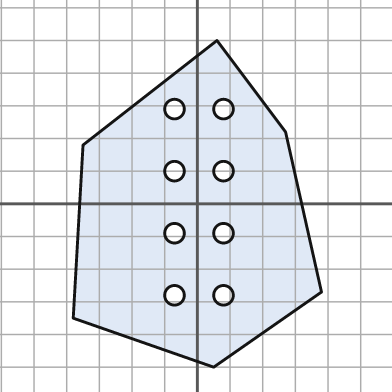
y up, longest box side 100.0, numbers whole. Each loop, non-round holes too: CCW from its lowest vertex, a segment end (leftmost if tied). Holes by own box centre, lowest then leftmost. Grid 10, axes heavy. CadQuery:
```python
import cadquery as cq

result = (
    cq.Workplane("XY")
    .moveTo(5.0, -50.0)
    .lineTo(38.0, -27.0)
    .lineTo(27.0, 22.0)
    .lineTo(6.0, 50.0)
    .lineTo(-35.0, 18.0)
    .lineTo(-38.0, -35.0)
    .close()
    .moveTo(-7.0, -28.0)
    .circle(3.0)
    .moveTo(8.0, -28.0)
    .circle(3.0)
    .moveTo(-7.0, -9.0)
    .circle(3.0)
    .moveTo(8.0, -9.0)
    .circle(3.0)
    .moveTo(-7.0, 10.0)
    .circle(3.0)
    .moveTo(8.0, 10.0)
    .circle(3.0)
    .moveTo(-7.0, 29.0)
    .circle(3.0)
    .moveTo(8.0, 29.0)
    .circle(3.0)
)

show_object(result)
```